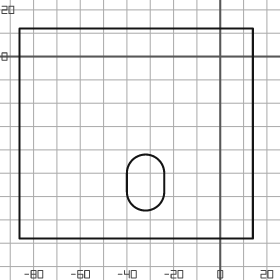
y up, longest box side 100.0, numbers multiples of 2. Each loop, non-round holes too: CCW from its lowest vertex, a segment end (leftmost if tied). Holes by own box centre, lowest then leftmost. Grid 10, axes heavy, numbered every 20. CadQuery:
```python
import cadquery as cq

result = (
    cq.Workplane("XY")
    .moveTo(-86.0, -78.0)
    .lineTo(14.0, -78.0)
    .lineTo(14.0, 12.0)
    .lineTo(-86.0, 12.0)
    .close()
    .moveTo(-40.0, -58.0)
    .threePointArc((-32.0, -66.0), (-24.0, -58.0))
    .lineTo(-24.0, -50.0)
    .threePointArc((-32.0, -42.0), (-40.0, -50.0))
    .close()
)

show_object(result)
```